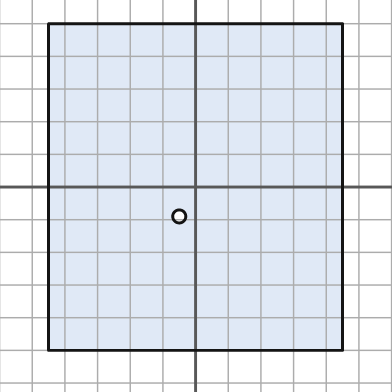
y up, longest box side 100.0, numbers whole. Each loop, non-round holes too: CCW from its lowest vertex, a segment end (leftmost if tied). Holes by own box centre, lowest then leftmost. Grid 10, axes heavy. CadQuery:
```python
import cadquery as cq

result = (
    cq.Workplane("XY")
    .moveTo(-45.0, -50.0)
    .lineTo(45.0, -50.0)
    .lineTo(45.0, 50.0)
    .lineTo(-45.0, 50.0)
    .close()
    .moveTo(-5.0, -9.0)
    .circle(2.0)
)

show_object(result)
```